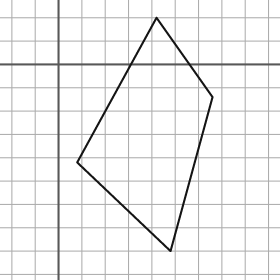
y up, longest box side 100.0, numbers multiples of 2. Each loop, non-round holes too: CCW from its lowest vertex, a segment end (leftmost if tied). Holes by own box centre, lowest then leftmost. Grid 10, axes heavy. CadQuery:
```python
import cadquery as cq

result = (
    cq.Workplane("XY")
    .moveTo(48.0, -80.0)
    .lineTo(66.0, -14.0)
    .lineTo(42.0, 20.0)
    .lineTo(8.0, -42.0)
    .close()
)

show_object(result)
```